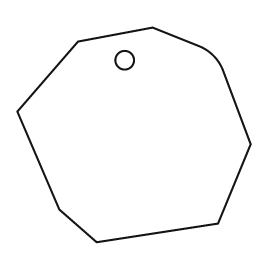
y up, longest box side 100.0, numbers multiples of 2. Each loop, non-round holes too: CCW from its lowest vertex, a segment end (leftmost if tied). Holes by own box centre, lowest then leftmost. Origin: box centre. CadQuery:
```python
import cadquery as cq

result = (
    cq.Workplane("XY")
    .moveTo(-16.0, -46.0)
    .lineTo(36.0, -38.0)
    .lineTo(50.0, -4.0)
    .lineTo(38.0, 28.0)
    .threePointArc((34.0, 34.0), (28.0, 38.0))
    .lineTo(8.0, 46.0)
    .lineTo(-24.0, 40.0)
    .lineTo(-50.0, 10.0)
    .lineTo(-32.0, -32.0)
    .close()
    .moveTo(-4.0, 32.0)
    .circle(4.0)
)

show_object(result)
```